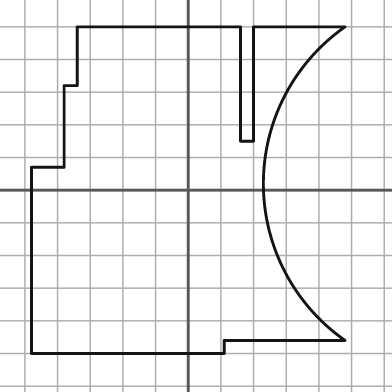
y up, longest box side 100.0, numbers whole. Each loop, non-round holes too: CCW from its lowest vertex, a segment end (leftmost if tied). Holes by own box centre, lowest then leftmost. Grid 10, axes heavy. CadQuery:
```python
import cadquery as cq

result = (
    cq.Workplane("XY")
    .moveTo(-48.0, -50.0)
    .lineTo(11.0, -50.0)
    .lineTo(11.0, -46.0)
    .lineTo(48.0, -46.0)
    .threePointArc((23.0, 2.0), (48.0, 50.0))
    .lineTo(20.0, 50.0)
    .lineTo(20.0, 15.0)
    .lineTo(16.0, 15.0)
    .lineTo(16.0, 50.0)
    .lineTo(-34.0, 50.0)
    .lineTo(-34.0, 32.0)
    .lineTo(-38.0, 32.0)
    .lineTo(-38.0, 7.0)
    .lineTo(-48.0, 7.0)
    .close()
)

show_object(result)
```